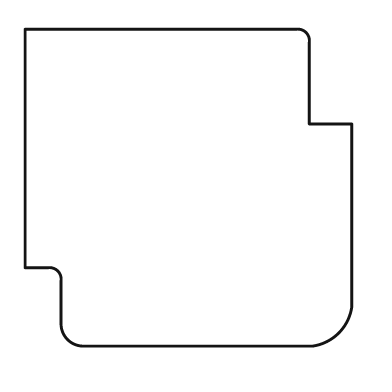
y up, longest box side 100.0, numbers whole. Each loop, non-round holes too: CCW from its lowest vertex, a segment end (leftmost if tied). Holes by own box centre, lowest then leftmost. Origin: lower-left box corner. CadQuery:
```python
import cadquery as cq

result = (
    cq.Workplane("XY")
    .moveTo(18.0, 0.0)
    .lineTo(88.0, 0.0)
    .threePointArc((96.0, 4.0), (100.0, 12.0))
    .lineTo(100.0, 68.0)
    .lineTo(87.0, 68.0)
    .lineTo(87.0, 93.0)
    .threePointArc((86.0, 96.0), (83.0, 97.0))
    .lineTo(0.0, 97.0)
    .lineTo(0.0, 24.0)
    .lineTo(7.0, 24.0)
    .threePointArc((10.0, 23.0), (11.0, 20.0))
    .lineTo(11.0, 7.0)
    .threePointArc((13.0, 2.0), (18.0, 0.0))
    .close()
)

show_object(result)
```